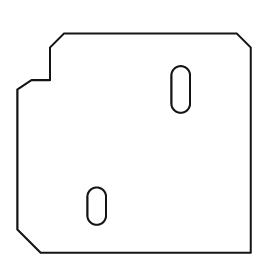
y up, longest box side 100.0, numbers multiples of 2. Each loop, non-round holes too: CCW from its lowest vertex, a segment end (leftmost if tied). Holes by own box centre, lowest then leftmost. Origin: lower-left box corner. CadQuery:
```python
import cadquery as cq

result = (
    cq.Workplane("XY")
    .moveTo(10.0, 0.0)
    .lineTo(100.0, 0.0)
    .lineTo(100.0, 88.0)
    .lineTo(94.0, 94.0)
    .lineTo(20.0, 94.0)
    .lineTo(14.0, 88.0)
    .lineTo(14.0, 74.0)
    .lineTo(6.0, 74.0)
    .lineTo(0.0, 70.0)
    .lineTo(0.0, 10.0)
    .close()
    .moveTo(30.0, 16.0)
    .threePointArc((34.0, 12.0), (38.0, 16.0))
    .lineTo(38.0, 24.0)
    .threePointArc((34.0, 28.0), (30.0, 24.0))
    .close()
    .moveTo(66.0, 64.0)
    .threePointArc((70.0, 60.0), (74.0, 64.0))
    .lineTo(74.0, 76.0)
    .threePointArc((70.0, 80.0), (66.0, 76.0))
    .close()
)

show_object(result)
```